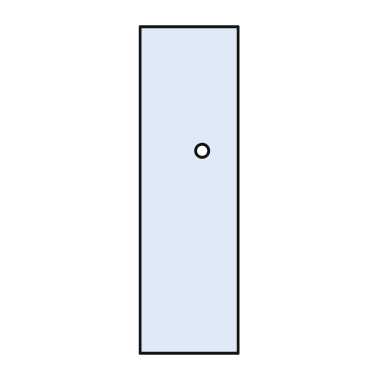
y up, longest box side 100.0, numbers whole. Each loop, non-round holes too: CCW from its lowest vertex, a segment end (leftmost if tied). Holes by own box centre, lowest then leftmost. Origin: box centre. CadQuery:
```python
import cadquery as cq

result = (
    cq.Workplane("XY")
    .moveTo(-15.0, -50.0)
    .lineTo(15.0, -50.0)
    .lineTo(15.0, 50.0)
    .lineTo(-15.0, 50.0)
    .close()
    .moveTo(4.0, 12.0)
    .circle(2.0)
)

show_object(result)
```